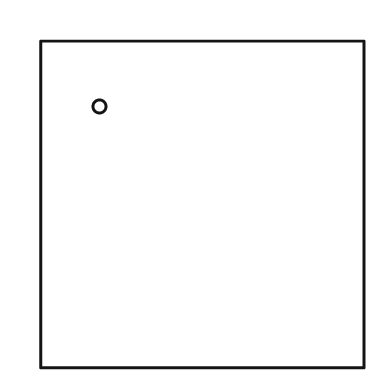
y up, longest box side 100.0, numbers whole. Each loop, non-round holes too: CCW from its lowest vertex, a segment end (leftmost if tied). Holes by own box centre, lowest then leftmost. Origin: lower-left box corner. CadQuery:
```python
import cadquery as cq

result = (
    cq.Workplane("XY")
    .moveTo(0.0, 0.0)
    .lineTo(99.0, 0.0)
    .lineTo(99.0, 100.0)
    .lineTo(0.0, 100.0)
    .close()
    .moveTo(18.0, 80.0)
    .circle(2.0)
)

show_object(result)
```